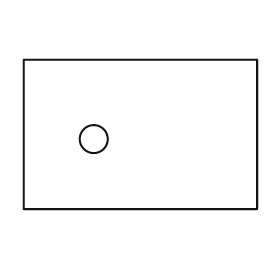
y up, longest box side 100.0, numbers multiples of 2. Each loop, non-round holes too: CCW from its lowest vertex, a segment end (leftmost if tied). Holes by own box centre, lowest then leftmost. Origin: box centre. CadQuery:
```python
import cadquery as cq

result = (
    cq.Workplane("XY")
    .moveTo(-50.0, -32.0)
    .lineTo(50.0, -32.0)
    .lineTo(50.0, 32.0)
    .lineTo(-50.0, 32.0)
    .close()
    .moveTo(-20.0, -2.0)
    .circle(6.0)
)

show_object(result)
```